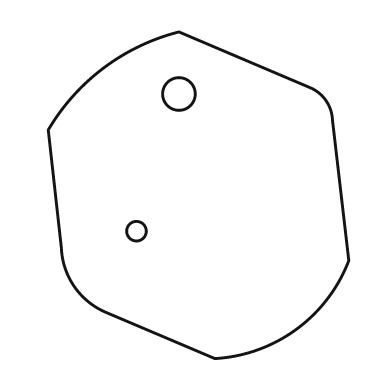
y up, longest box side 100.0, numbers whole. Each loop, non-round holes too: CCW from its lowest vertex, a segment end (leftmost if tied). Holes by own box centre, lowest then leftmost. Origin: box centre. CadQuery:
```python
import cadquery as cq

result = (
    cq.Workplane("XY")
    .moveTo(5.0, -50.0)
    .threePointArc((30.0, -41.0), (46.0, -20.0))
    .lineTo(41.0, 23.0)
    .threePointArc((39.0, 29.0), (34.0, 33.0))
    .lineTo(-6.0, 50.0)
    .threePointArc((-29.0, 39.0), (-46.0, 20.0))
    .lineTo(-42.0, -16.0)
    .threePointArc((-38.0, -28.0), (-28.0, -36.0))
    .close()
    .moveTo(-19.0, -11.0)
    .circle(3.0)
    .moveTo(-6.0, 31.0)
    .circle(5.0)
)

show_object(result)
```